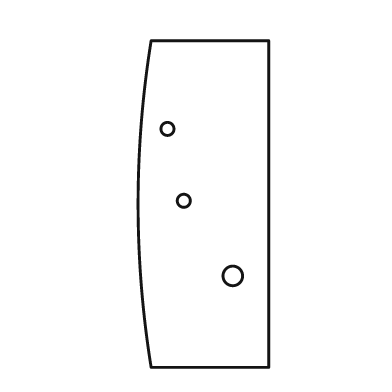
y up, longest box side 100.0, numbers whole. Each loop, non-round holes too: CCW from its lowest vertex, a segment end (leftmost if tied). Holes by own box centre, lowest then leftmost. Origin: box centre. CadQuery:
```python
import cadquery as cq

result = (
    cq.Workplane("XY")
    .moveTo(-16.0, -50.0)
    .lineTo(20.0, -50.0)
    .lineTo(20.0, 50.0)
    .lineTo(-16.0, 50.0)
    .threePointArc((-20.0, 0.0), (-16.0, -50.0))
    .close()
    .moveTo(9.0, -22.0)
    .circle(3.0)
    .moveTo(-6.0, 1.0)
    .circle(2.0)
    .moveTo(-11.0, 23.0)
    .circle(2.0)
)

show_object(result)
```